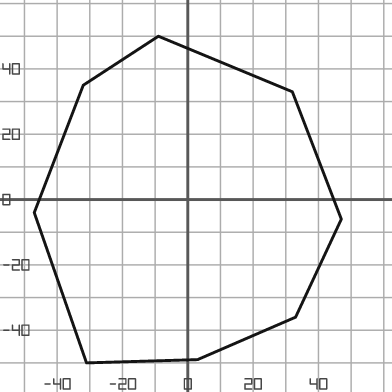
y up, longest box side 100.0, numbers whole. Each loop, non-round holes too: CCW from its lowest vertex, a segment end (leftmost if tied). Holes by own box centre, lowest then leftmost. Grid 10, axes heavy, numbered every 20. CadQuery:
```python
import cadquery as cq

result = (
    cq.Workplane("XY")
    .moveTo(-31.0, -50.0)
    .lineTo(3.0, -49.0)
    .lineTo(33.0, -36.0)
    .lineTo(47.0, -6.0)
    .lineTo(32.0, 33.0)
    .lineTo(-9.0, 50.0)
    .lineTo(-32.0, 35.0)
    .lineTo(-47.0, -4.0)
    .close()
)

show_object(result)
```